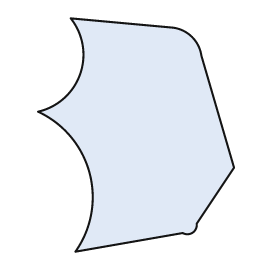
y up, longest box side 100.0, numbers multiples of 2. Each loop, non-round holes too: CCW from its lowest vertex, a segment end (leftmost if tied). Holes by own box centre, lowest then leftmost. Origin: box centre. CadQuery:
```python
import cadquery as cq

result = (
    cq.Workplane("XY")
    .moveTo(-26.0, -50.0)
    .lineTo(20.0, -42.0)
    .threePointArc((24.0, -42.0), (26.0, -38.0))
    .lineTo(42.0, -14.0)
    .lineTo(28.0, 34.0)
    .threePointArc((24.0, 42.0), (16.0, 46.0))
    .lineTo(-28.0, 50.0)
    .threePointArc((-24.0, 26.0), (-42.0, 10.0))
    .threePointArc((-20.0, -16.0), (-26.0, -50.0))
    .close()
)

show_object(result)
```